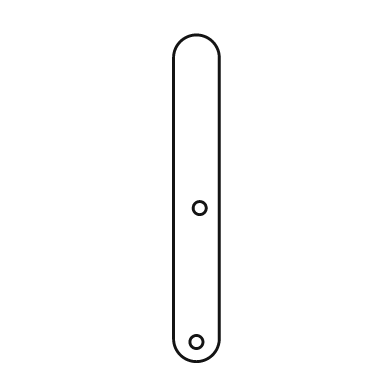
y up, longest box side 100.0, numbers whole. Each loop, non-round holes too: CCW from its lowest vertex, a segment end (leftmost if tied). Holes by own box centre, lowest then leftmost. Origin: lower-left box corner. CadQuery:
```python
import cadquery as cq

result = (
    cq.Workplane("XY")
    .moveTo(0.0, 7.0)
    .threePointArc((7.0, 0.0), (14.0, 7.0))
    .lineTo(14.0, 93.0)
    .threePointArc((7.0, 100.0), (0.0, 93.0))
    .close()
    .moveTo(7.0, 6.0)
    .circle(2.0)
    .moveTo(8.0, 47.0)
    .circle(2.0)
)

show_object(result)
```